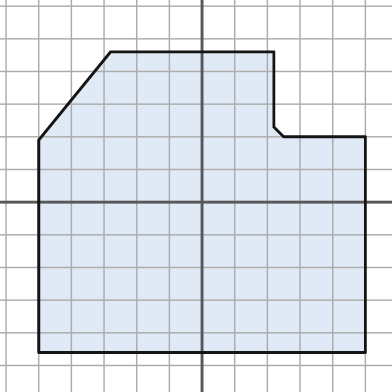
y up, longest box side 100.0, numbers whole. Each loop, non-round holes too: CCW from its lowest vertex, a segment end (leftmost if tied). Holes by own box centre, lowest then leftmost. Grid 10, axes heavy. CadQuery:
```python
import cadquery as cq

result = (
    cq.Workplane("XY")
    .moveTo(-50.0, -46.0)
    .lineTo(50.0, -46.0)
    .lineTo(50.0, 20.0)
    .lineTo(25.0, 20.0)
    .lineTo(22.0, 23.0)
    .lineTo(22.0, 46.0)
    .lineTo(-28.0, 46.0)
    .lineTo(-50.0, 19.0)
    .close()
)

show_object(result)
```